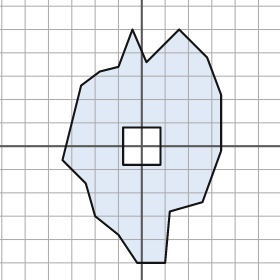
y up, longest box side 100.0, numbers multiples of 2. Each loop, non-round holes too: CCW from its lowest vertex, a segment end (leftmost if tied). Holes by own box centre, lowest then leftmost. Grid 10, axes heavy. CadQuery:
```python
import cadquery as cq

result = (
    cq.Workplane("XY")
    .moveTo(-2.0, -50.0)
    .lineTo(10.0, -50.0)
    .lineTo(12.0, -28.0)
    .lineTo(26.0, -24.0)
    .lineTo(34.0, -2.0)
    .lineTo(34.0, 22.0)
    .lineTo(28.0, 38.0)
    .lineTo(16.0, 50.0)
    .lineTo(2.0, 36.0)
    .lineTo(-4.0, 50.0)
    .lineTo(-10.0, 34.0)
    .lineTo(-18.0, 32.0)
    .lineTo(-26.0, 26.0)
    .lineTo(-34.0, -6.0)
    .lineTo(-24.0, -16.0)
    .lineTo(-20.0, -30.0)
    .lineTo(-10.0, -38.0)
    .close()
    .moveTo(-8.0, -8.0)
    .lineTo(8.0, -8.0)
    .lineTo(8.0, 8.0)
    .lineTo(-8.0, 8.0)
    .close()
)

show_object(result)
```